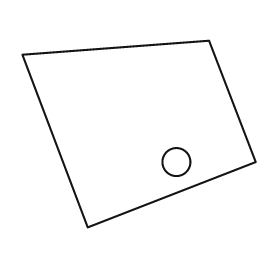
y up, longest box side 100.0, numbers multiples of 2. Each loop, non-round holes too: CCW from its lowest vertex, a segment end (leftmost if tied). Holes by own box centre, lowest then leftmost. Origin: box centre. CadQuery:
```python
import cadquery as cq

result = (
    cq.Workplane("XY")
    .moveTo(-22.0, -40.0)
    .lineTo(50.0, -12.0)
    .lineTo(30.0, 40.0)
    .lineTo(-50.0, 34.0)
    .close()
    .moveTo(16.0, -12.0)
    .circle(6.0)
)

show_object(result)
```